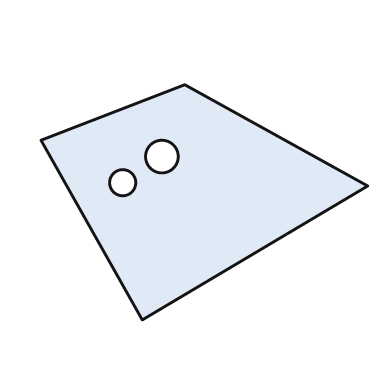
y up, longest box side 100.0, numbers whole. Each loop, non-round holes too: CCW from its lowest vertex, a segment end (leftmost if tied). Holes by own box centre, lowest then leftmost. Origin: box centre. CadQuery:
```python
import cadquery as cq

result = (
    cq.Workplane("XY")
    .moveTo(-19.0, -36.0)
    .lineTo(50.0, 5.0)
    .lineTo(-6.0, 36.0)
    .lineTo(-50.0, 19.0)
    .close()
    .moveTo(-25.0, 6.0)
    .circle(4.0)
    .moveTo(-13.0, 14.0)
    .circle(5.0)
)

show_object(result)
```